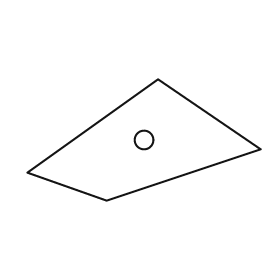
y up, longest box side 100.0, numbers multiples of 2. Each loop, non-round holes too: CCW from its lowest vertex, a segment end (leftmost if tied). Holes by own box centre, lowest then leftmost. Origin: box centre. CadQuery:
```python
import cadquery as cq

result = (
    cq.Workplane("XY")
    .moveTo(-16.0, -26.0)
    .lineTo(50.0, -4.0)
    .lineTo(6.0, 26.0)
    .lineTo(-50.0, -14.0)
    .close()
    .moveTo(0.0, 0.0)
    .circle(4.0)
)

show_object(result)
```